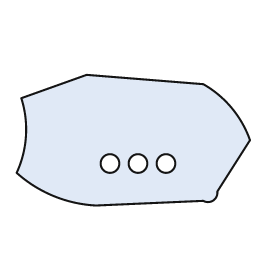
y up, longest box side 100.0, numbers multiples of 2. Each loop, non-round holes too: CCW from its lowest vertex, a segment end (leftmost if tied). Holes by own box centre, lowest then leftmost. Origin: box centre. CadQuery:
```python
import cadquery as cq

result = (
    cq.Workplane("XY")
    .moveTo(-16.0, -28.0)
    .lineTo(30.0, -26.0)
    .threePointArc((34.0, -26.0), (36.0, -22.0))
    .lineTo(50.0, 0.0)
    .threePointArc((42.0, 14.0), (30.0, 24.0))
    .lineTo(-20.0, 28.0)
    .lineTo(-48.0, 18.0)
    .threePointArc((-46.0, 2.0), (-50.0, -14.0))
    .threePointArc((-34.0, -24.0), (-16.0, -28.0))
    .close()
    .moveTo(-10.0, -10.0)
    .circle(4.0)
    .moveTo(2.0, -10.0)
    .circle(4.0)
    .moveTo(14.0, -10.0)
    .circle(4.0)
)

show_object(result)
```